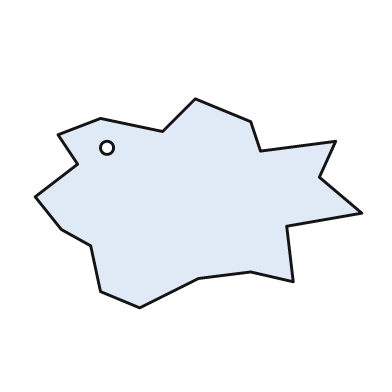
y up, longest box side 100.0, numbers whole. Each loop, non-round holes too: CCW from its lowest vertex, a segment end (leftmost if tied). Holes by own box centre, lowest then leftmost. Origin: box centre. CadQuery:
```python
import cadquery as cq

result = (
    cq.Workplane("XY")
    .moveTo(-18.0, -32.0)
    .lineTo(0.0, -23.0)
    .lineTo(16.0, -21.0)
    .lineTo(29.0, -24.0)
    .lineTo(27.0, -7.0)
    .lineTo(50.0, -3.0)
    .lineTo(37.0, 8.0)
    .lineTo(42.0, 19.0)
    .lineTo(19.0, 16.0)
    .lineTo(16.0, 25.0)
    .lineTo(-1.0, 32.0)
    .lineTo(-11.0, 22.0)
    .lineTo(-30.0, 26.0)
    .lineTo(-43.0, 21.0)
    .lineTo(-37.0, 12.0)
    .lineTo(-50.0, 2.0)
    .lineTo(-42.0, -8.0)
    .lineTo(-33.0, -13.0)
    .lineTo(-30.0, -27.0)
    .close()
    .moveTo(-28.0, 17.0)
    .circle(2.0)
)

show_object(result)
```